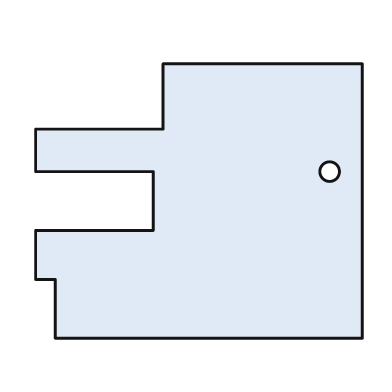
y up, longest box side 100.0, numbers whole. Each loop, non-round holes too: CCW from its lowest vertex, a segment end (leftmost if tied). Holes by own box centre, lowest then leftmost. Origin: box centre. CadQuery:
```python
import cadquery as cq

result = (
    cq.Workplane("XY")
    .moveTo(-44.0, -42.0)
    .lineTo(50.0, -42.0)
    .lineTo(50.0, 42.0)
    .lineTo(-11.0, 42.0)
    .lineTo(-11.0, 22.0)
    .lineTo(-50.0, 22.0)
    .lineTo(-50.0, 9.0)
    .lineTo(-14.0, 9.0)
    .lineTo(-14.0, -9.0)
    .lineTo(-50.0, -9.0)
    .lineTo(-50.0, -24.0)
    .lineTo(-44.0, -24.0)
    .close()
    .moveTo(40.0, 9.0)
    .circle(3.0)
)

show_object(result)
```